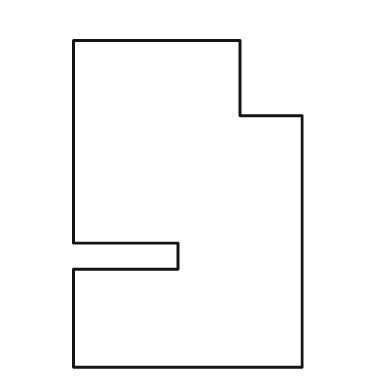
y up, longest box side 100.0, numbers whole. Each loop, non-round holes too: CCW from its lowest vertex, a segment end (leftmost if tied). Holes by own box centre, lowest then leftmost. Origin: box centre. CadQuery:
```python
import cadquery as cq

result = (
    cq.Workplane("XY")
    .moveTo(-35.0, -50.0)
    .lineTo(35.0, -50.0)
    .lineTo(35.0, 27.0)
    .lineTo(16.0, 27.0)
    .lineTo(16.0, 50.0)
    .lineTo(-35.0, 50.0)
    .lineTo(-35.0, -12.0)
    .lineTo(-3.0, -12.0)
    .lineTo(-3.0, -20.0)
    .lineTo(-35.0, -20.0)
    .close()
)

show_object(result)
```